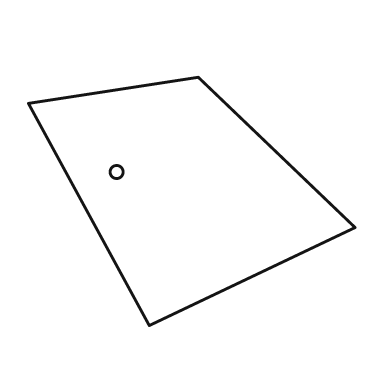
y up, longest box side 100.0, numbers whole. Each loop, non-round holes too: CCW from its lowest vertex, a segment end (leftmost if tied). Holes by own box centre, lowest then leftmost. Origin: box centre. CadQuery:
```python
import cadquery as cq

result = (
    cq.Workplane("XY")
    .moveTo(-13.0, -38.0)
    .lineTo(50.0, -8.0)
    .lineTo(2.0, 38.0)
    .lineTo(-50.0, 30.0)
    .close()
    .moveTo(-23.0, 9.0)
    .circle(2.0)
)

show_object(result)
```